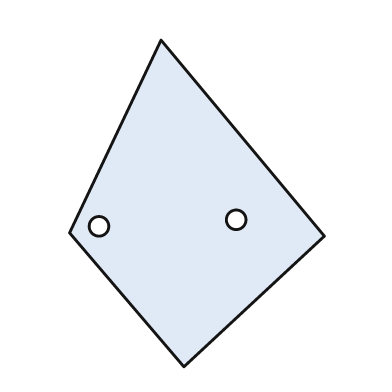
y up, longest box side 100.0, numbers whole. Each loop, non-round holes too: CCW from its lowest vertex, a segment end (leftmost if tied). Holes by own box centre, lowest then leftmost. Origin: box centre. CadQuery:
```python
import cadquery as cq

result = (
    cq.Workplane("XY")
    .moveTo(-4.0, -50.0)
    .lineTo(39.0, -10.0)
    .lineTo(-11.0, 50.0)
    .lineTo(-39.0, -9.0)
    .close()
    .moveTo(-30.0, -7.0)
    .circle(3.0)
    .moveTo(12.0, -5.0)
    .circle(3.0)
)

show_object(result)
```